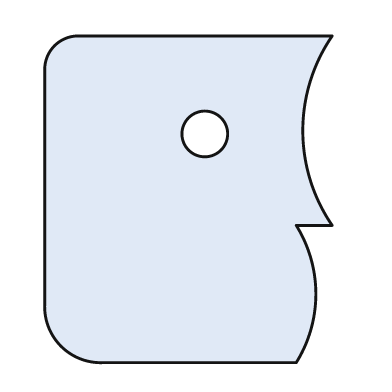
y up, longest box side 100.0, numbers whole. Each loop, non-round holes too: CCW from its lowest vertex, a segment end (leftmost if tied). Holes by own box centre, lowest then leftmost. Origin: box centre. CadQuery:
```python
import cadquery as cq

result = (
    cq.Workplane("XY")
    .moveTo(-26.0, -50.0)
    .lineTo(33.0, -50.0)
    .threePointArc((39.0, -29.0), (33.0, -8.0))
    .lineTo(44.0, -8.0)
    .threePointArc((35.0, 21.0), (44.0, 50.0))
    .lineTo(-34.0, 50.0)
    .threePointArc((-41.0, 47.0), (-44.0, 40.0))
    .lineTo(-44.0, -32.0)
    .threePointArc((-39.0, -45.0), (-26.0, -50.0))
    .close()
    .moveTo(5.0, 20.0)
    .circle(7.0)
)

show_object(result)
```